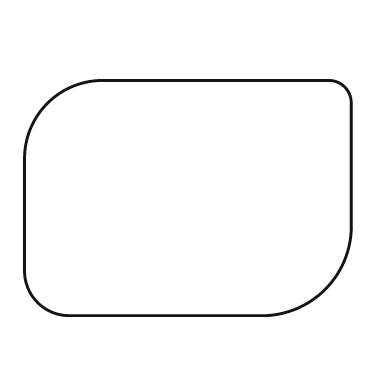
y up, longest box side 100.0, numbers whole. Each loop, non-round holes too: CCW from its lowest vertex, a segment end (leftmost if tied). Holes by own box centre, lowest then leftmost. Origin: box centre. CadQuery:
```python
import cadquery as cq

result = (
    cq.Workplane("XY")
    .moveTo(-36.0, -36.0)
    .lineTo(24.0, -36.0)
    .threePointArc((42.0, -28.0), (50.0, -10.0))
    .lineTo(50.0, 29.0)
    .threePointArc((48.0, 34.0), (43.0, 36.0))
    .lineTo(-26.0, 36.0)
    .threePointArc((-43.0, 29.0), (-50.0, 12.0))
    .lineTo(-50.0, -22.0)
    .threePointArc((-46.0, -32.0), (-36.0, -36.0))
    .close()
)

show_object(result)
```